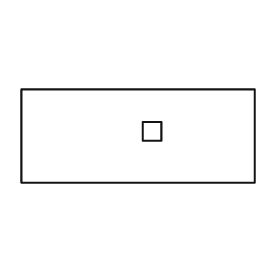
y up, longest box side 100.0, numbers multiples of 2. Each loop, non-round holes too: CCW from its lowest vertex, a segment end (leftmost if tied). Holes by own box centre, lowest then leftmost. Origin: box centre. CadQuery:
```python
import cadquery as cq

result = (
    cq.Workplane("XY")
    .moveTo(-50.0, -20.0)
    .lineTo(50.0, -20.0)
    .lineTo(50.0, 20.0)
    .lineTo(-50.0, 20.0)
    .close()
    .moveTo(2.0, -2.0)
    .lineTo(10.0, -2.0)
    .lineTo(10.0, 6.0)
    .lineTo(2.0, 6.0)
    .close()
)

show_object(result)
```